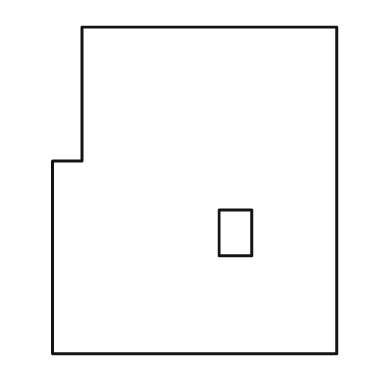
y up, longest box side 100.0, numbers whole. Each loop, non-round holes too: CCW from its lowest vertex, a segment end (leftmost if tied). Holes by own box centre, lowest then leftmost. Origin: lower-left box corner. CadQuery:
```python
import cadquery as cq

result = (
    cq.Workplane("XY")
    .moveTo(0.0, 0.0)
    .lineTo(87.0, 0.0)
    .lineTo(87.0, 100.0)
    .lineTo(9.0, 100.0)
    .lineTo(9.0, 59.0)
    .lineTo(0.0, 59.0)
    .close()
    .moveTo(51.0, 30.0)
    .lineTo(61.0, 30.0)
    .lineTo(61.0, 44.0)
    .lineTo(51.0, 44.0)
    .close()
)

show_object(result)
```